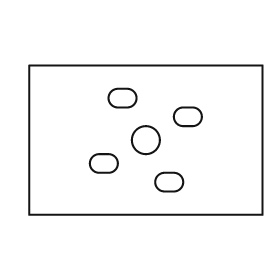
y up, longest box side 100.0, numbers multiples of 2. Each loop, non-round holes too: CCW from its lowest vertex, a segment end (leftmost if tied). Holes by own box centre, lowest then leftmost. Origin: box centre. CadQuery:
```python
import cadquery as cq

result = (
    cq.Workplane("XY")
    .moveTo(-50.0, -32.0)
    .lineTo(50.0, -32.0)
    .lineTo(50.0, 32.0)
    .lineTo(-50.0, 32.0)
    .close()
    .moveTo(8.0, -22.0)
    .lineTo(12.0, -22.0)
    .threePointArc((16.0, -18.0), (12.0, -14.0))
    .lineTo(8.0, -14.0)
    .threePointArc((4.0, -18.0), (8.0, -22.0))
    .close()
    .moveTo(-20.0, -14.0)
    .lineTo(-16.0, -14.0)
    .threePointArc((-12.0, -10.0), (-16.0, -6.0))
    .lineTo(-20.0, -6.0)
    .threePointArc((-24.0, -10.0), (-20.0, -14.0))
    .close()
    .moveTo(0.0, 0.0)
    .circle(6.0)
    .moveTo(16.0, 6.0)
    .lineTo(20.0, 6.0)
    .threePointArc((24.0, 10.0), (20.0, 14.0))
    .lineTo(16.0, 14.0)
    .threePointArc((12.0, 10.0), (16.0, 6.0))
    .close()
    .moveTo(-12.0, 14.0)
    .lineTo(-8.0, 14.0)
    .threePointArc((-4.0, 18.0), (-8.0, 22.0))
    .lineTo(-12.0, 22.0)
    .threePointArc((-16.0, 18.0), (-12.0, 14.0))
    .close()
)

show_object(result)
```